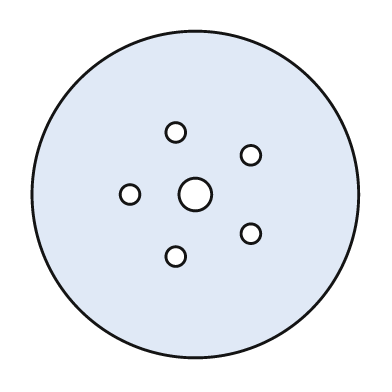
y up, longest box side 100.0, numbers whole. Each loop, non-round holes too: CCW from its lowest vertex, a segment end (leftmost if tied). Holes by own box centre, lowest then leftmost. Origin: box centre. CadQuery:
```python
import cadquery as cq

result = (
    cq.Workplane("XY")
    .moveTo(0.0, 0.0)
    .circle(50.0)
    .moveTo(-6.0, -19.0)
    .circle(3.0)
    .moveTo(17.0, -12.0)
    .circle(3.0)
    .moveTo(-20.0, 0.0)
    .circle(3.0)
    .moveTo(0.0, 0.0)
    .circle(5.0)
    .moveTo(17.0, 12.0)
    .circle(3.0)
    .moveTo(-6.0, 19.0)
    .circle(3.0)
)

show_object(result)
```